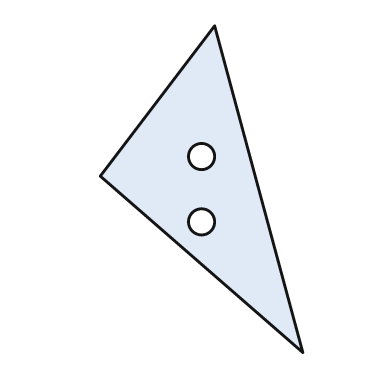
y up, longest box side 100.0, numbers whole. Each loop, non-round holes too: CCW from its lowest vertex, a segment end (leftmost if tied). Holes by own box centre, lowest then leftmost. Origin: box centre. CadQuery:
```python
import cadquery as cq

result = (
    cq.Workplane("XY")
    .moveTo(31.0, -50.0)
    .lineTo(4.0, 50.0)
    .lineTo(-31.0, 4.0)
    .close()
    .moveTo(0.0, -10.0)
    .circle(4.0)
    .moveTo(0.0, 10.0)
    .circle(4.0)
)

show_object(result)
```